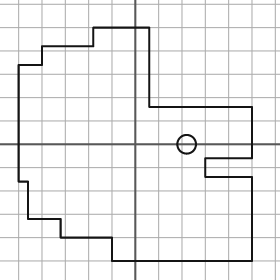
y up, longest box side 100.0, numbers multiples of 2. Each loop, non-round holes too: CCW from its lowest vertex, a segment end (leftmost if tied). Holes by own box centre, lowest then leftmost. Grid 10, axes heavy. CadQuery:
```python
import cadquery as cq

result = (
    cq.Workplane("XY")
    .moveTo(-10.0, -50.0)
    .lineTo(50.0, -50.0)
    .lineTo(50.0, -14.0)
    .lineTo(30.0, -14.0)
    .lineTo(30.0, -6.0)
    .lineTo(50.0, -6.0)
    .lineTo(50.0, 16.0)
    .lineTo(6.0, 16.0)
    .lineTo(6.0, 50.0)
    .lineTo(-18.0, 50.0)
    .lineTo(-18.0, 42.0)
    .lineTo(-40.0, 42.0)
    .lineTo(-40.0, 34.0)
    .lineTo(-50.0, 34.0)
    .lineTo(-50.0, -16.0)
    .lineTo(-46.0, -16.0)
    .lineTo(-46.0, -32.0)
    .lineTo(-32.0, -32.0)
    .lineTo(-32.0, -40.0)
    .lineTo(-10.0, -40.0)
    .close()
    .moveTo(22.0, 0.0)
    .circle(4.0)
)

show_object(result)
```